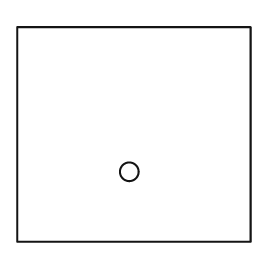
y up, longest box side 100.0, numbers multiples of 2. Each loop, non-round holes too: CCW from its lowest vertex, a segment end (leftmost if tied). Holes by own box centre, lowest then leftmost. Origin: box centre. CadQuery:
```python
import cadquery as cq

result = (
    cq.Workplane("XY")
    .moveTo(-50.0, -46.0)
    .lineTo(50.0, -46.0)
    .lineTo(50.0, 46.0)
    .lineTo(-50.0, 46.0)
    .close()
    .moveTo(-2.0, -16.0)
    .circle(4.0)
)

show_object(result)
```